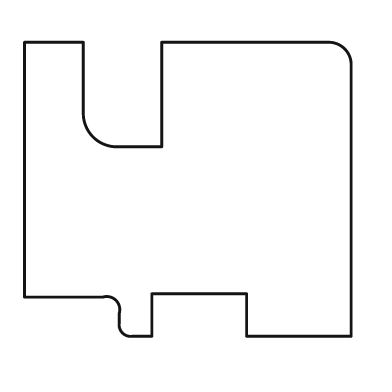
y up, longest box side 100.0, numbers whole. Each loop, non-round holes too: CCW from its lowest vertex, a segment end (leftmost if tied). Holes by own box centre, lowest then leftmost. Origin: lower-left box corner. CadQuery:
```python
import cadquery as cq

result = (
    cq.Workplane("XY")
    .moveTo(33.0, 0.0)
    .lineTo(39.0, 0.0)
    .lineTo(39.0, 13.0)
    .lineTo(68.0, 13.0)
    .lineTo(68.0, 0.0)
    .lineTo(100.0, 0.0)
    .lineTo(100.0, 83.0)
    .threePointArc((98.0, 88.0), (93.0, 90.0))
    .lineTo(42.0, 90.0)
    .lineTo(42.0, 58.0)
    .lineTo(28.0, 58.0)
    .threePointArc((21.0, 61.0), (18.0, 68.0))
    .lineTo(18.0, 90.0)
    .lineTo(0.0, 90.0)
    .lineTo(0.0, 12.0)
    .lineTo(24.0, 12.0)
    .threePointArc((28.0, 11.0), (29.0, 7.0))
    .lineTo(29.0, 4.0)
    .threePointArc((30.0, 1.0), (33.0, 0.0))
    .close()
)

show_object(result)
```